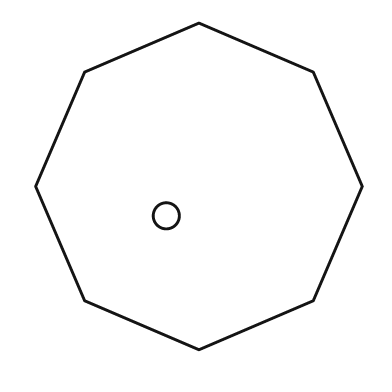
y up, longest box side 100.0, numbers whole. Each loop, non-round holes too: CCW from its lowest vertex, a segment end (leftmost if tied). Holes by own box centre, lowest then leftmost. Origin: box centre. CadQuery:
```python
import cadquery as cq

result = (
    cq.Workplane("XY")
    .moveTo(0.0, -50.0)
    .lineTo(35.0, -35.0)
    .lineTo(50.0, 0.0)
    .lineTo(35.0, 35.0)
    .lineTo(0.0, 50.0)
    .lineTo(-35.0, 35.0)
    .lineTo(-50.0, 0.0)
    .lineTo(-35.0, -35.0)
    .close()
    .moveTo(-10.0, -9.0)
    .circle(4.0)
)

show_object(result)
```